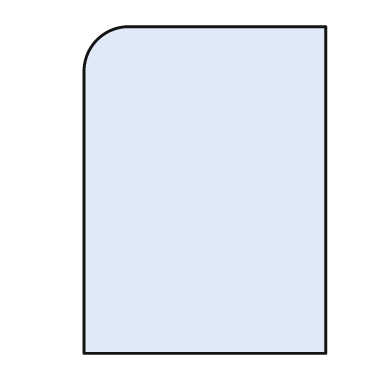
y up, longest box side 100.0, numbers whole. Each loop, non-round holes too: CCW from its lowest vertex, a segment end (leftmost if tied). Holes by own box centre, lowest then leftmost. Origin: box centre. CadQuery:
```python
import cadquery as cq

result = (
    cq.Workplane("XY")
    .moveTo(-37.0, -50.0)
    .lineTo(37.0, -50.0)
    .lineTo(37.0, 50.0)
    .lineTo(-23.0, 50.0)
    .threePointArc((-33.0, 46.0), (-37.0, 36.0))
    .close()
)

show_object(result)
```